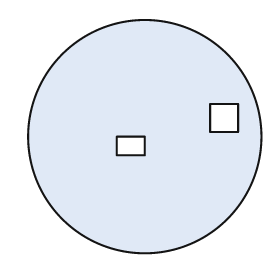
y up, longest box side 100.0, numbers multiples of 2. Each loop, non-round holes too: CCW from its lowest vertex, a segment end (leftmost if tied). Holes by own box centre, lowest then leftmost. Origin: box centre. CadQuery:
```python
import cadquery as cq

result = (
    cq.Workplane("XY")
    .moveTo(0.0, 0.0)
    .circle(50.0)
    .moveTo(-12.0, -8.0)
    .lineTo(0.0, -8.0)
    .lineTo(0.0, 0.0)
    .lineTo(-12.0, 0.0)
    .close()
    .moveTo(28.0, 2.0)
    .lineTo(40.0, 2.0)
    .lineTo(40.0, 14.0)
    .lineTo(28.0, 14.0)
    .close()
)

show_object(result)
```